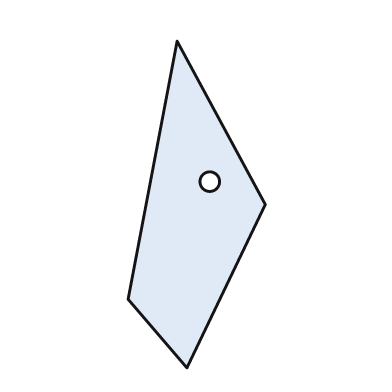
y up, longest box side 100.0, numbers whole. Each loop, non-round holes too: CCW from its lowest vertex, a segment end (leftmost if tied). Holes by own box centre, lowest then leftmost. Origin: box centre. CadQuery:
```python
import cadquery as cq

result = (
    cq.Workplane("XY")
    .moveTo(-3.0, -50.0)
    .lineTo(21.0, 0.0)
    .lineTo(-6.0, 50.0)
    .lineTo(-21.0, -29.0)
    .close()
    .moveTo(4.0, 7.0)
    .circle(3.0)
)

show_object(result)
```